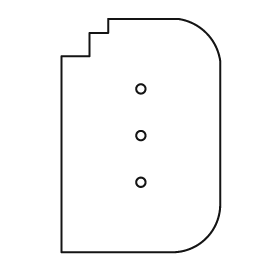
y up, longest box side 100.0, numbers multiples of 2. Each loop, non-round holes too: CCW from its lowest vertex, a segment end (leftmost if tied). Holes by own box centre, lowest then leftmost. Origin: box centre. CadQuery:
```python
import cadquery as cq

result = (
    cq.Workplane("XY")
    .moveTo(-34.0, -50.0)
    .lineTo(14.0, -50.0)
    .threePointArc((28.0, -44.0), (34.0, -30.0))
    .lineTo(34.0, 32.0)
    .threePointArc((28.0, 44.0), (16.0, 50.0))
    .lineTo(-14.0, 50.0)
    .lineTo(-14.0, 44.0)
    .lineTo(-22.0, 44.0)
    .lineTo(-22.0, 34.0)
    .lineTo(-34.0, 34.0)
    .close()
    .moveTo(0.0, -20.0)
    .circle(2.0)
    .moveTo(0.0, 0.0)
    .circle(2.0)
    .moveTo(0.0, 20.0)
    .circle(2.0)
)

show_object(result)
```